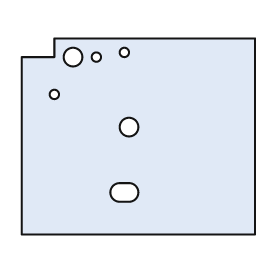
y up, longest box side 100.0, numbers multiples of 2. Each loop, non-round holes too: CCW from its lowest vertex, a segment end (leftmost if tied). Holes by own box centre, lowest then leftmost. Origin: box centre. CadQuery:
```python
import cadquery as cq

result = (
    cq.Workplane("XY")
    .moveTo(-50.0, -42.0)
    .lineTo(50.0, -42.0)
    .lineTo(50.0, 42.0)
    .lineTo(-36.0, 42.0)
    .lineTo(-36.0, 34.0)
    .lineTo(-50.0, 34.0)
    .close()
    .moveTo(-8.0, -28.0)
    .lineTo(-4.0, -28.0)
    .threePointArc((0.0, -24.0), (-4.0, -20.0))
    .lineTo(-8.0, -20.0)
    .threePointArc((-12.0, -24.0), (-8.0, -28.0))
    .close()
    .moveTo(-4.0, 4.0)
    .circle(4.0)
    .moveTo(-36.0, 18.0)
    .circle(2.0)
    .moveTo(-28.0, 34.0)
    .circle(4.0)
    .moveTo(-18.0, 34.0)
    .circle(2.0)
    .moveTo(-6.0, 36.0)
    .circle(2.0)
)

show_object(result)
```